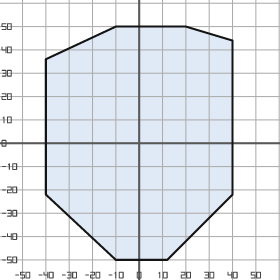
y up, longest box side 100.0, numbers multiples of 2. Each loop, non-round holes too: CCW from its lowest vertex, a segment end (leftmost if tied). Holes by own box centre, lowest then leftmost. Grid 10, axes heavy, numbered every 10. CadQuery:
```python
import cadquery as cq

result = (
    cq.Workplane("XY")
    .moveTo(-10.0, -50.0)
    .lineTo(12.0, -50.0)
    .lineTo(40.0, -22.0)
    .lineTo(40.0, 44.0)
    .lineTo(20.0, 50.0)
    .lineTo(-10.0, 50.0)
    .lineTo(-40.0, 36.0)
    .lineTo(-40.0, -22.0)
    .close()
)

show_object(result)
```